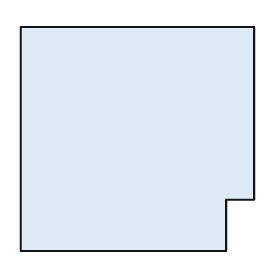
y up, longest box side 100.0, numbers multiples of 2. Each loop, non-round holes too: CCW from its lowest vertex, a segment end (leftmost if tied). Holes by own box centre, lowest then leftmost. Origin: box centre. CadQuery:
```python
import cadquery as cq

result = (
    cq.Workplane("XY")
    .moveTo(-50.0, -48.0)
    .lineTo(38.0, -48.0)
    .lineTo(38.0, -26.0)
    .lineTo(50.0, -26.0)
    .lineTo(50.0, 48.0)
    .lineTo(-50.0, 48.0)
    .close()
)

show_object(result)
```